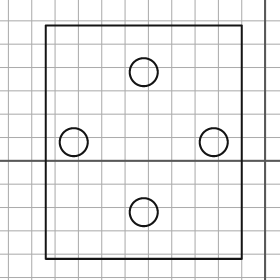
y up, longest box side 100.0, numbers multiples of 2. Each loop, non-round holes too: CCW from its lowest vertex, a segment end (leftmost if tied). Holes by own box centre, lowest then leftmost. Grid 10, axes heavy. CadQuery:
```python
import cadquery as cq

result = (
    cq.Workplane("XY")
    .moveTo(-94.0, -42.0)
    .lineTo(-10.0, -42.0)
    .lineTo(-10.0, 58.0)
    .lineTo(-94.0, 58.0)
    .close()
    .moveTo(-52.0, -22.0)
    .circle(6.0)
    .moveTo(-82.0, 8.0)
    .circle(6.0)
    .moveTo(-22.0, 8.0)
    .circle(6.0)
    .moveTo(-52.0, 38.0)
    .circle(6.0)
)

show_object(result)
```